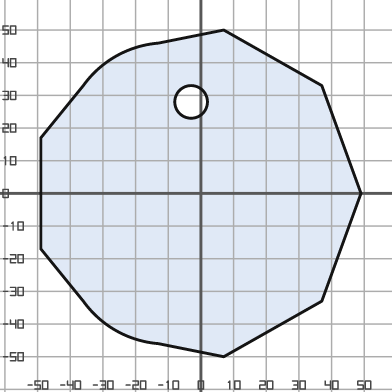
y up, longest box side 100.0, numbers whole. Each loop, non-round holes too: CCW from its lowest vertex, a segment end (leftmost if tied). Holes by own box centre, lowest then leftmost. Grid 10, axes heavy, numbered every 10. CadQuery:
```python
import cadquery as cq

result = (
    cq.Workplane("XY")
    .moveTo(7.0, -50.0)
    .lineTo(37.0, -33.0)
    .lineTo(49.0, 0.0)
    .lineTo(37.0, 33.0)
    .lineTo(7.0, 50.0)
    .lineTo(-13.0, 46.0)
    .threePointArc((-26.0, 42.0), (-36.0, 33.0))
    .lineTo(-49.0, 17.0)
    .lineTo(-49.0, -17.0)
    .lineTo(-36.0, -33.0)
    .threePointArc((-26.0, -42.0), (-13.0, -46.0))
    .close()
    .moveTo(-3.0, 28.0)
    .circle(5.0)
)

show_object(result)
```